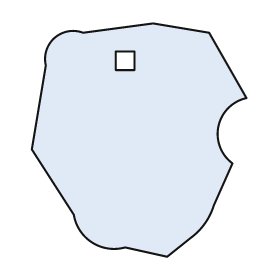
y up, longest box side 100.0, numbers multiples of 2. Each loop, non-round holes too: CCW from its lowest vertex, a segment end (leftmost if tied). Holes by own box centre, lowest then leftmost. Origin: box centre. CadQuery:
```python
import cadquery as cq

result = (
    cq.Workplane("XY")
    .moveTo(12.0, -50.0)
    .lineTo(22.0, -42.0)
    .threePointArc((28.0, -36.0), (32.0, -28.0))
    .lineTo(40.0, -10.0)
    .threePointArc((34.0, 6.0), (46.0, 18.0))
    .lineTo(30.0, 46.0)
    .lineTo(6.0, 50.0)
    .lineTo(-24.0, 46.0)
    .threePointArc((-36.0, 44.0), (-40.0, 32.0))
    .lineTo(-46.0, -4.0)
    .lineTo(-28.0, -32.0)
    .threePointArc((-20.0, -44.0), (-6.0, -46.0))
    .close()
    .moveTo(-10.0, 30.0)
    .lineTo(-2.0, 30.0)
    .lineTo(-2.0, 38.0)
    .lineTo(-10.0, 38.0)
    .close()
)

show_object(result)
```